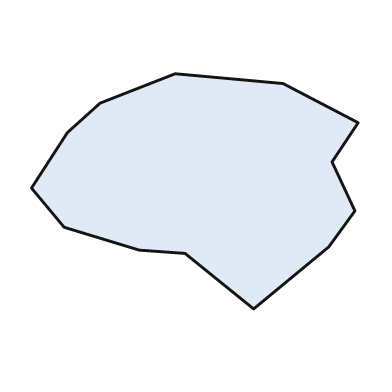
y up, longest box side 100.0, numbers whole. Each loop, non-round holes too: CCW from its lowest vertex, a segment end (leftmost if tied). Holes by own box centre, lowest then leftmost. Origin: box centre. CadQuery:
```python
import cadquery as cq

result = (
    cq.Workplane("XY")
    .moveTo(18.0, -36.0)
    .lineTo(41.0, -17.0)
    .lineTo(49.0, -6.0)
    .lineTo(42.0, 9.0)
    .lineTo(50.0, 21.0)
    .lineTo(27.0, 33.0)
    .lineTo(-6.0, 36.0)
    .lineTo(-29.0, 27.0)
    .lineTo(-39.0, 18.0)
    .lineTo(-50.0, 1.0)
    .lineTo(-40.0, -11.0)
    .lineTo(-17.0, -18.0)
    .lineTo(-3.0, -19.0)
    .close()
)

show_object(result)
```